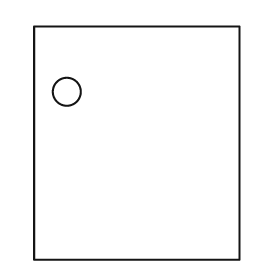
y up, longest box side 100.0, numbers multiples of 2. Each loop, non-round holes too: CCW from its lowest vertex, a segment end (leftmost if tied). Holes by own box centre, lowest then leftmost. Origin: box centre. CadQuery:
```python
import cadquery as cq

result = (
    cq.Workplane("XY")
    .moveTo(-44.0, -50.0)
    .lineTo(44.0, -50.0)
    .lineTo(44.0, 50.0)
    .lineTo(-44.0, 50.0)
    .close()
    .moveTo(-30.0, 22.0)
    .circle(6.0)
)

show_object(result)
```